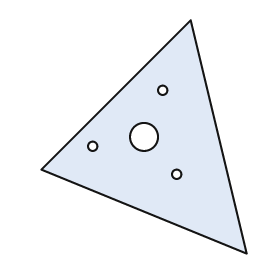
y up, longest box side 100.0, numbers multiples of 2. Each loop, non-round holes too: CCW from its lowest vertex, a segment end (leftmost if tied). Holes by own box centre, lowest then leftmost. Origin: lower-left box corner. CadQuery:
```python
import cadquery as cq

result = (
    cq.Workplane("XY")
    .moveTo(88.0, 0.0)
    .lineTo(64.0, 100.0)
    .lineTo(0.0, 36.0)
    .close()
    .moveTo(58.0, 34.0)
    .circle(2.0)
    .moveTo(22.0, 46.0)
    .circle(2.0)
    .moveTo(44.0, 50.0)
    .circle(6.0)
    .moveTo(52.0, 70.0)
    .circle(2.0)
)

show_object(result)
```